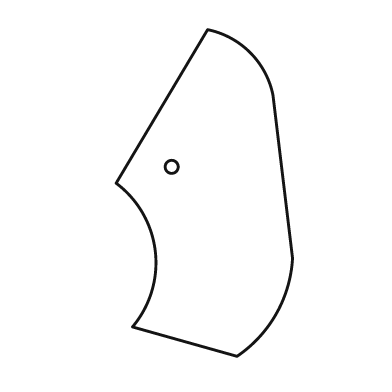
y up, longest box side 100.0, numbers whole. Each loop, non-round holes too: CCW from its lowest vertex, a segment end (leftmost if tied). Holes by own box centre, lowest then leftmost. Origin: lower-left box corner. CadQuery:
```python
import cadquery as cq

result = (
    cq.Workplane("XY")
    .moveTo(37.0, 0.0)
    .threePointArc((49.0, 13.0), (54.0, 30.0))
    .lineTo(48.0, 80.0)
    .threePointArc((41.0, 93.0), (28.0, 100.0))
    .lineTo(0.0, 53.0)
    .threePointArc((12.0, 32.0), (5.0, 9.0))
    .close()
    .moveTo(17.0, 58.0)
    .circle(2.0)
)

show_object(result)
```